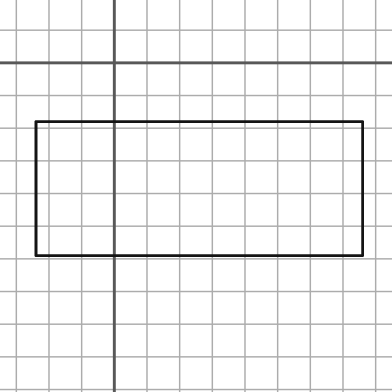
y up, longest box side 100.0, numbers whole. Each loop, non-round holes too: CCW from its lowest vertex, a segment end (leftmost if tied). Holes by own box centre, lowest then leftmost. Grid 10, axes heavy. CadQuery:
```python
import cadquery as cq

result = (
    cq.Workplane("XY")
    .moveTo(-24.0, -59.0)
    .lineTo(76.0, -59.0)
    .lineTo(76.0, -18.0)
    .lineTo(-24.0, -18.0)
    .close()
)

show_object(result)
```